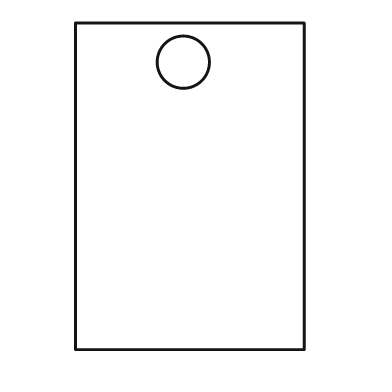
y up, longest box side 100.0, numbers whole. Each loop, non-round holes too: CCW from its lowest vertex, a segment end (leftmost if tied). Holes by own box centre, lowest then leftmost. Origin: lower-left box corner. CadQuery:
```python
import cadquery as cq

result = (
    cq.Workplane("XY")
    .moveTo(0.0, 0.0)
    .lineTo(70.0, 0.0)
    .lineTo(70.0, 100.0)
    .lineTo(0.0, 100.0)
    .close()
    .moveTo(33.0, 88.0)
    .circle(8.0)
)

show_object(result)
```